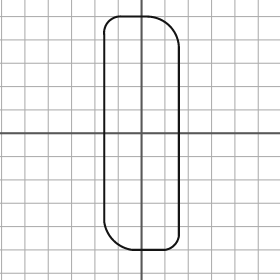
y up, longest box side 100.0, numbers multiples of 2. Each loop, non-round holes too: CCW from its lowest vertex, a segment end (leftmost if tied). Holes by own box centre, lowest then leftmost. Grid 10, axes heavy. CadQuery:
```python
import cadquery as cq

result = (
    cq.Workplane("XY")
    .moveTo(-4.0, -50.0)
    .lineTo(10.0, -50.0)
    .threePointArc((14.0, -48.0), (16.0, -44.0))
    .lineTo(16.0, 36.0)
    .threePointArc((12.0, 46.0), (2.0, 50.0))
    .lineTo(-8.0, 50.0)
    .threePointArc((-14.0, 48.0), (-16.0, 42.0))
    .lineTo(-16.0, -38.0)
    .threePointArc((-12.0, -46.0), (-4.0, -50.0))
    .close()
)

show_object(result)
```